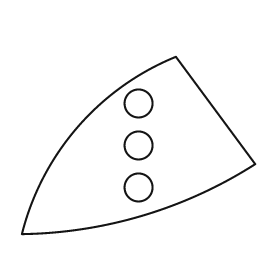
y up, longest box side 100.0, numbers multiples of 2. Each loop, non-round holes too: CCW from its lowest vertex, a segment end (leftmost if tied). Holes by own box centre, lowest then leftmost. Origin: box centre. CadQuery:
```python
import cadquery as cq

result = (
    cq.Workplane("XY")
    .moveTo(-50.0, -38.0)
    .threePointArc((2.0, -30.0), (50.0, -8.0))
    .lineTo(16.0, 38.0)
    .threePointArc((-26.0, 8.0), (-50.0, -38.0))
    .close()
    .moveTo(0.0, -18.0)
    .circle(6.0)
    .moveTo(0.0, 0.0)
    .circle(6.0)
    .moveTo(0.0, 18.0)
    .circle(6.0)
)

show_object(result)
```